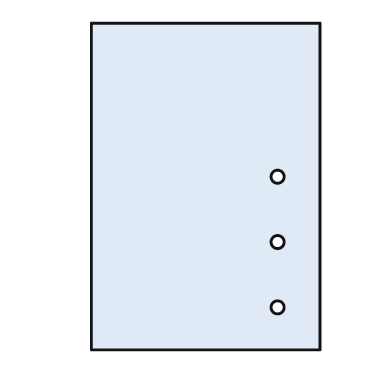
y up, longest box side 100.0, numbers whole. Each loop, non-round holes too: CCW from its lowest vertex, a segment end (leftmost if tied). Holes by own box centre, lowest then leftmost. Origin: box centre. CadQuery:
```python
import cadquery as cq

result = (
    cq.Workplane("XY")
    .moveTo(-35.0, -50.0)
    .lineTo(35.0, -50.0)
    .lineTo(35.0, 50.0)
    .lineTo(-35.0, 50.0)
    .close()
    .moveTo(22.0, -37.0)
    .circle(2.0)
    .moveTo(22.0, -17.0)
    .circle(2.0)
    .moveTo(22.0, 3.0)
    .circle(2.0)
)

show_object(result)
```